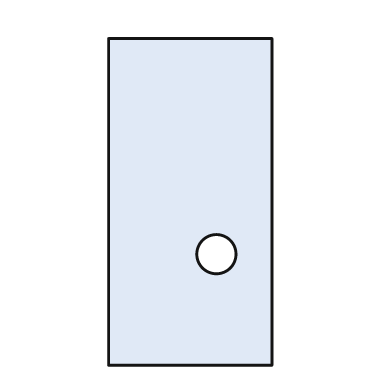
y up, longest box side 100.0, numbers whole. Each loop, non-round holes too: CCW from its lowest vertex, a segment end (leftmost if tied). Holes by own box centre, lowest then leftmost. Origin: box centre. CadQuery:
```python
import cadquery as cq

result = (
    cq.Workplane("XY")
    .moveTo(-25.0, -50.0)
    .lineTo(25.0, -50.0)
    .lineTo(25.0, 50.0)
    .lineTo(-25.0, 50.0)
    .close()
    .moveTo(8.0, -16.0)
    .circle(6.0)
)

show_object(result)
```